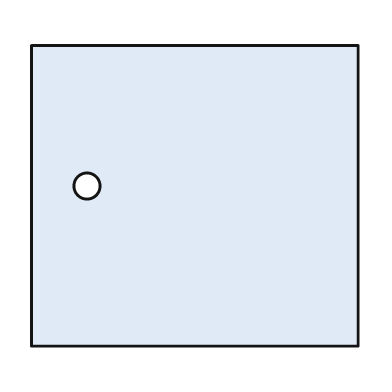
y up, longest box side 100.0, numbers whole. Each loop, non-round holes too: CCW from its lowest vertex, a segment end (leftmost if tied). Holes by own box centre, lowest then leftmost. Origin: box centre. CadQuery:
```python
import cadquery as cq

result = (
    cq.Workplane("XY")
    .moveTo(-50.0, -46.0)
    .lineTo(50.0, -46.0)
    .lineTo(50.0, 46.0)
    .lineTo(-50.0, 46.0)
    .close()
    .moveTo(-33.0, 3.0)
    .circle(4.0)
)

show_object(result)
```